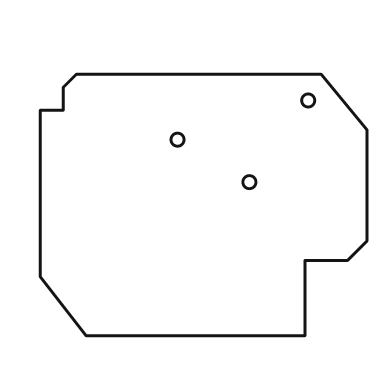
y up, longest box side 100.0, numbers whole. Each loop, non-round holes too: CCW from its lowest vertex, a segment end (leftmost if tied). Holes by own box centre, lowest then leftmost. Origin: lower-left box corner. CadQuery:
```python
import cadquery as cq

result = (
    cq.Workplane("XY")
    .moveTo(14.0, 0.0)
    .lineTo(81.0, 0.0)
    .lineTo(81.0, 23.0)
    .lineTo(94.0, 23.0)
    .lineTo(100.0, 29.0)
    .lineTo(100.0, 63.0)
    .lineTo(86.0, 80.0)
    .lineTo(11.0, 80.0)
    .lineTo(7.0, 76.0)
    .lineTo(7.0, 69.0)
    .lineTo(0.0, 69.0)
    .lineTo(0.0, 18.0)
    .close()
    .moveTo(64.0, 47.0)
    .circle(2.0)
    .moveTo(42.0, 60.0)
    .circle(2.0)
    .moveTo(82.0, 72.0)
    .circle(2.0)
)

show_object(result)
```